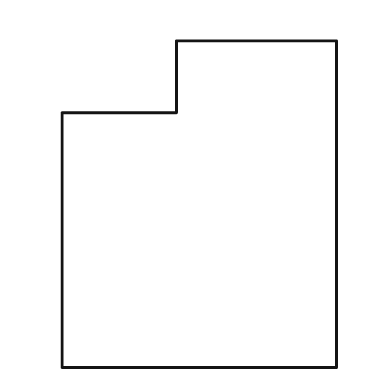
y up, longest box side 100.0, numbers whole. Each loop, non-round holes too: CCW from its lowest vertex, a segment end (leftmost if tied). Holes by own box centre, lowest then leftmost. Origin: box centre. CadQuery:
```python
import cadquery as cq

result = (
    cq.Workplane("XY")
    .moveTo(-42.0, -50.0)
    .lineTo(42.0, -50.0)
    .lineTo(42.0, 50.0)
    .lineTo(-7.0, 50.0)
    .lineTo(-7.0, 28.0)
    .lineTo(-42.0, 28.0)
    .close()
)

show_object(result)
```